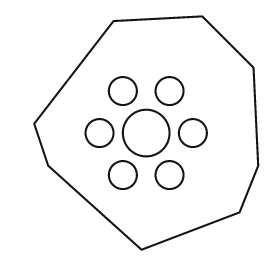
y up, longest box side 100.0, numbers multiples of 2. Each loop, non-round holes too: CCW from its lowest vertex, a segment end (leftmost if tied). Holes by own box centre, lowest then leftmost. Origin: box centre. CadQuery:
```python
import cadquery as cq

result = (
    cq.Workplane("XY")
    .moveTo(-2.0, -50.0)
    .lineTo(40.0, -34.0)
    .lineTo(48.0, -14.0)
    .lineTo(46.0, 28.0)
    .lineTo(24.0, 50.0)
    .lineTo(-14.0, 48.0)
    .lineTo(-48.0, 4.0)
    .lineTo(-42.0, -14.0)
    .close()
    .moveTo(-10.0, -18.0)
    .circle(6.0)
    .moveTo(10.0, -18.0)
    .circle(6.0)
    .moveTo(-20.0, 0.0)
    .circle(6.0)
    .moveTo(0.0, 0.0)
    .circle(10.0)
    .moveTo(20.0, 0.0)
    .circle(6.0)
    .moveTo(-10.0, 18.0)
    .circle(6.0)
    .moveTo(10.0, 18.0)
    .circle(6.0)
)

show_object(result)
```